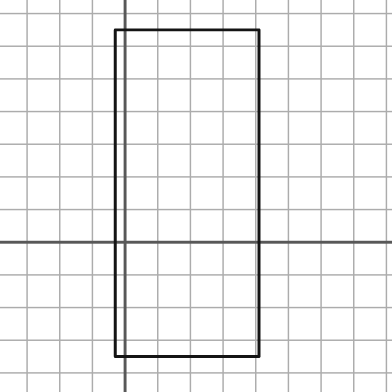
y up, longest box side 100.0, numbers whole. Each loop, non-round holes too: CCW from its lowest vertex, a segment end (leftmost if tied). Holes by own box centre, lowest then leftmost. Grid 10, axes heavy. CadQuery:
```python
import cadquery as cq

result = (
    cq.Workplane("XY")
    .moveTo(-3.0, -35.0)
    .lineTo(41.0, -35.0)
    .lineTo(41.0, 65.0)
    .lineTo(-3.0, 65.0)
    .close()
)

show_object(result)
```